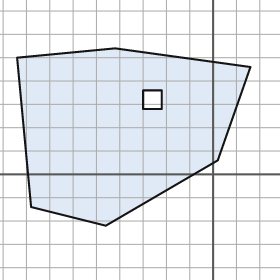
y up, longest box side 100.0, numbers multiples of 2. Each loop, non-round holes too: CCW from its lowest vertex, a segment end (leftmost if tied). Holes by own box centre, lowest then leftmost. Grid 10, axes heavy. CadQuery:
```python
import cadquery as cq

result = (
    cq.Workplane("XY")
    .moveTo(-46.0, -22.0)
    .lineTo(2.0, 6.0)
    .lineTo(16.0, 46.0)
    .lineTo(-42.0, 54.0)
    .lineTo(-84.0, 50.0)
    .lineTo(-78.0, -14.0)
    .close()
    .moveTo(-30.0, 28.0)
    .lineTo(-22.0, 28.0)
    .lineTo(-22.0, 36.0)
    .lineTo(-30.0, 36.0)
    .close()
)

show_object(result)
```